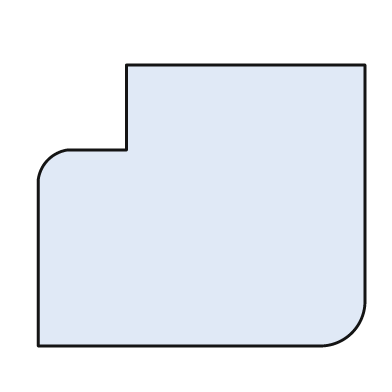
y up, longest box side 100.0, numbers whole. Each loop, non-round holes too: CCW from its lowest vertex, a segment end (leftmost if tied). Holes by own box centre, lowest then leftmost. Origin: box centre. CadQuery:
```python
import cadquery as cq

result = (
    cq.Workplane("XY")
    .moveTo(-50.0, -43.0)
    .lineTo(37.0, -43.0)
    .threePointArc((46.0, -39.0), (50.0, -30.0))
    .lineTo(50.0, 43.0)
    .lineTo(-23.0, 43.0)
    .lineTo(-23.0, 17.0)
    .lineTo(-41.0, 17.0)
    .threePointArc((-47.0, 14.0), (-50.0, 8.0))
    .close()
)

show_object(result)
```